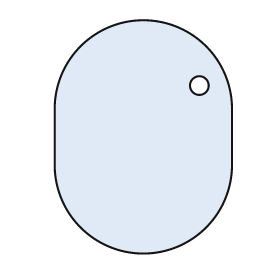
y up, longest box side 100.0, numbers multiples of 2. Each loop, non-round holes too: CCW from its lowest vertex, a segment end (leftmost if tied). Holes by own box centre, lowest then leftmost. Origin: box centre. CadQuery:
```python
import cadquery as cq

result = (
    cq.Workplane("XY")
    .moveTo(-38.0, -12.0)
    .threePointArc((0.0, -50.0), (38.0, -12.0))
    .lineTo(38.0, 12.0)
    .threePointArc((0.0, 50.0), (-38.0, 12.0))
    .close()
    .moveTo(24.0, 22.0)
    .circle(4.0)
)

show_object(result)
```